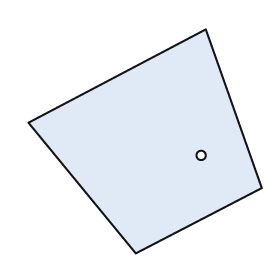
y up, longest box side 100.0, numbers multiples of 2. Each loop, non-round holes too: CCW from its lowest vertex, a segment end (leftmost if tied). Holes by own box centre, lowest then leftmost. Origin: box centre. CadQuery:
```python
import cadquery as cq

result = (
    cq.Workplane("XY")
    .moveTo(-4.0, -48.0)
    .lineTo(50.0, -20.0)
    .lineTo(26.0, 48.0)
    .lineTo(-50.0, 8.0)
    .close()
    .moveTo(24.0, -6.0)
    .circle(2.0)
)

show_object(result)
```